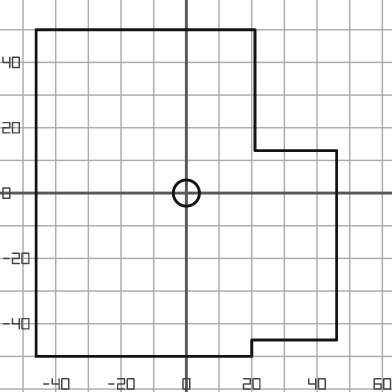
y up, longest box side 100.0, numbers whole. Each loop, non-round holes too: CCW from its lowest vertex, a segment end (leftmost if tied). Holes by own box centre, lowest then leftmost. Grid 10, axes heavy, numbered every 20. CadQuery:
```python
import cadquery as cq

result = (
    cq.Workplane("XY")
    .moveTo(-46.0, -50.0)
    .lineTo(20.0, -50.0)
    .lineTo(20.0, -45.0)
    .lineTo(46.0, -45.0)
    .lineTo(46.0, 13.0)
    .lineTo(21.0, 13.0)
    .lineTo(21.0, 50.0)
    .lineTo(-46.0, 50.0)
    .close()
    .moveTo(0.0, 0.0)
    .circle(4.0)
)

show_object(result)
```